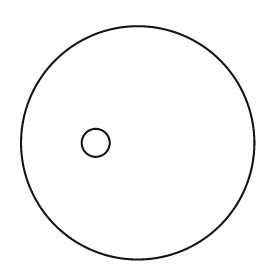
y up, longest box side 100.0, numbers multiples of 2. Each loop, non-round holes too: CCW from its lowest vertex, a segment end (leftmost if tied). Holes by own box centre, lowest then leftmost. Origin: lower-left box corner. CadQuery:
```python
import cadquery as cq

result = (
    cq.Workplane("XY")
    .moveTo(50.0, 50.0)
    .circle(50.0)
    .moveTo(32.0, 50.0)
    .circle(6.0)
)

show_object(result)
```